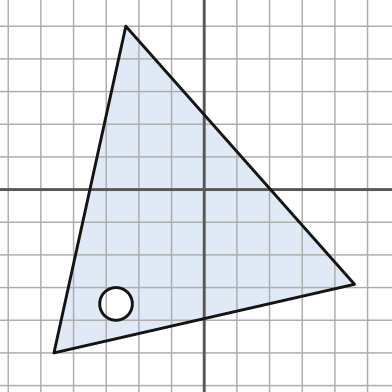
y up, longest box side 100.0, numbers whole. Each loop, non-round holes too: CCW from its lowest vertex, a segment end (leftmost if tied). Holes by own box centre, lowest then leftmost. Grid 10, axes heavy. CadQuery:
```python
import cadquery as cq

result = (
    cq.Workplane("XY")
    .moveTo(-46.0, -50.0)
    .lineTo(46.0, -29.0)
    .lineTo(-24.0, 50.0)
    .close()
    .moveTo(-27.0, -35.0)
    .circle(5.0)
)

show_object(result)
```